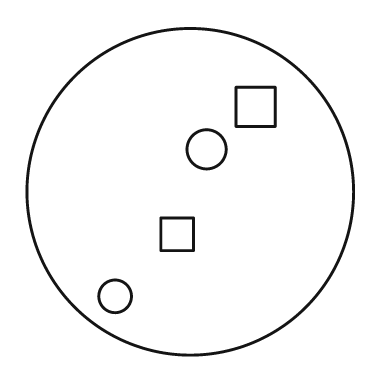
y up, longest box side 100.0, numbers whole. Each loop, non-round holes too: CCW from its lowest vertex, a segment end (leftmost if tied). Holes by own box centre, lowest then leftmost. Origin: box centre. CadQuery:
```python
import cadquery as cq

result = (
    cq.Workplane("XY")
    .moveTo(0.0, 0.0)
    .circle(50.0)
    .moveTo(-23.0, -32.0)
    .circle(5.0)
    .moveTo(-9.0, -18.0)
    .lineTo(1.0, -18.0)
    .lineTo(1.0, -8.0)
    .lineTo(-9.0, -8.0)
    .close()
    .moveTo(5.0, 13.0)
    .circle(6.0)
    .moveTo(14.0, 20.0)
    .lineTo(26.0, 20.0)
    .lineTo(26.0, 32.0)
    .lineTo(14.0, 32.0)
    .close()
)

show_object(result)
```